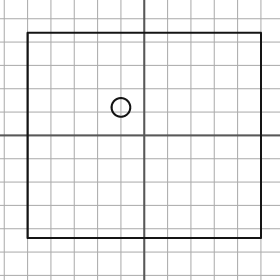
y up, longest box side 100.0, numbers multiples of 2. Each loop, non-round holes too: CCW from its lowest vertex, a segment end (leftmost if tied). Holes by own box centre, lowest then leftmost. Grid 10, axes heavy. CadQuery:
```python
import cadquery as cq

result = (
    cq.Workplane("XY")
    .moveTo(-50.0, -44.0)
    .lineTo(50.0, -44.0)
    .lineTo(50.0, 44.0)
    .lineTo(-50.0, 44.0)
    .close()
    .moveTo(-10.0, 12.0)
    .circle(4.0)
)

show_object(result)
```